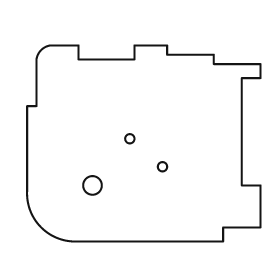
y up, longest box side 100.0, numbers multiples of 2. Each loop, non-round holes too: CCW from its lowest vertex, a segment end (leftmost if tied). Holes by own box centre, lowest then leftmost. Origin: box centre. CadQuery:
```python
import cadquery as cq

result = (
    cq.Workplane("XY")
    .moveTo(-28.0, -42.0)
    .lineTo(34.0, -42.0)
    .lineTo(34.0, -36.0)
    .lineTo(50.0, -36.0)
    .lineTo(50.0, -18.0)
    .lineTo(42.0, -18.0)
    .lineTo(42.0, 28.0)
    .lineTo(50.0, 28.0)
    .lineTo(50.0, 34.0)
    .lineTo(30.0, 34.0)
    .lineTo(30.0, 38.0)
    .lineTo(10.0, 38.0)
    .lineTo(10.0, 42.0)
    .lineTo(-4.0, 42.0)
    .lineTo(-4.0, 36.0)
    .lineTo(-28.0, 36.0)
    .lineTo(-28.0, 42.0)
    .lineTo(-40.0, 42.0)
    .threePointArc((-44.0, 40.0), (-46.0, 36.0))
    .lineTo(-46.0, 16.0)
    .lineTo(-50.0, 16.0)
    .lineTo(-50.0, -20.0)
    .threePointArc((-44.0, -36.0), (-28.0, -42.0))
    .close()
    .moveTo(-22.0, -18.0)
    .circle(4.0)
    .moveTo(8.0, -10.0)
    .circle(2.0)
    .moveTo(-6.0, 2.0)
    .circle(2.0)
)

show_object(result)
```